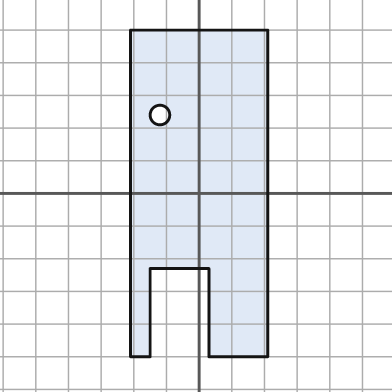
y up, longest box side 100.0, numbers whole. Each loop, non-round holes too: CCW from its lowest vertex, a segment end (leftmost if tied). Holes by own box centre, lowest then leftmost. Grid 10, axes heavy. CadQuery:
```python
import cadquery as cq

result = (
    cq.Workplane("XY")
    .moveTo(-21.0, -50.0)
    .lineTo(-15.0, -50.0)
    .lineTo(-15.0, -23.0)
    .lineTo(3.0, -23.0)
    .lineTo(3.0, -50.0)
    .lineTo(21.0, -50.0)
    .lineTo(21.0, 50.0)
    .lineTo(-21.0, 50.0)
    .close()
    .moveTo(-12.0, 24.0)
    .circle(3.0)
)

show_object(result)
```